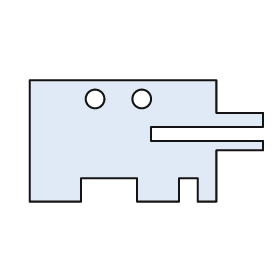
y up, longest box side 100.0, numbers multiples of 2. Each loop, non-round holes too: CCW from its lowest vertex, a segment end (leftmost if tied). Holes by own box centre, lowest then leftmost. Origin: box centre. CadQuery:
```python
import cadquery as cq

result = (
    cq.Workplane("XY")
    .moveTo(-50.0, -26.0)
    .lineTo(-28.0, -26.0)
    .lineTo(-28.0, -16.0)
    .lineTo(-4.0, -16.0)
    .lineTo(-4.0, -26.0)
    .lineTo(14.0, -26.0)
    .lineTo(14.0, -16.0)
    .lineTo(22.0, -16.0)
    .lineTo(22.0, -26.0)
    .lineTo(30.0, -26.0)
    .lineTo(30.0, -4.0)
    .lineTo(50.0, -4.0)
    .lineTo(50.0, 0.0)
    .lineTo(2.0, 0.0)
    .lineTo(2.0, 6.0)
    .lineTo(50.0, 6.0)
    .lineTo(50.0, 12.0)
    .lineTo(30.0, 12.0)
    .lineTo(30.0, 26.0)
    .lineTo(-50.0, 26.0)
    .close()
    .moveTo(-22.0, 18.0)
    .circle(4.0)
    .moveTo(-2.0, 18.0)
    .circle(4.0)
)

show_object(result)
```